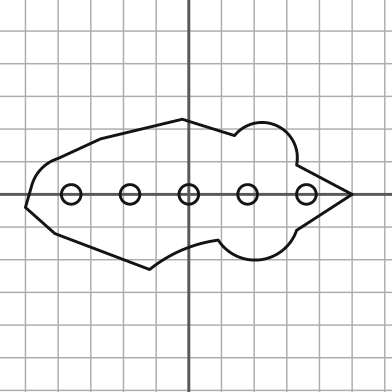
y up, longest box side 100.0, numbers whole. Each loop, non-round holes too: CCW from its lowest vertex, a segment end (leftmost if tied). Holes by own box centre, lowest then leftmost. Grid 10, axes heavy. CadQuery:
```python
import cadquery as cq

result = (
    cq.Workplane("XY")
    .moveTo(-12.0, -23.0)
    .threePointArc((-2.0, -17.0), (9.0, -14.0))
    .threePointArc((22.0, -20.0), (33.0, -11.0))
    .lineTo(50.0, 0.0)
    .lineTo(33.0, 9.0)
    .threePointArc((27.0, 21.0), (14.0, 18.0))
    .lineTo(-2.0, 23.0)
    .lineTo(-27.0, 17.0)
    .lineTo(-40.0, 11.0)
    .threePointArc((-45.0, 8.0), (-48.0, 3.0))
    .lineTo(-50.0, -4.0)
    .lineTo(-41.0, -12.0)
    .close()
    .moveTo(-36.0, 0.0)
    .circle(3.0)
    .moveTo(-18.0, 0.0)
    .circle(3.0)
    .moveTo(0.0, 0.0)
    .circle(3.0)
    .moveTo(18.0, 0.0)
    .circle(3.0)
    .moveTo(36.0, 0.0)
    .circle(3.0)
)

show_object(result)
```